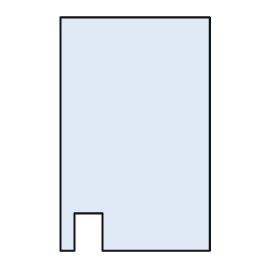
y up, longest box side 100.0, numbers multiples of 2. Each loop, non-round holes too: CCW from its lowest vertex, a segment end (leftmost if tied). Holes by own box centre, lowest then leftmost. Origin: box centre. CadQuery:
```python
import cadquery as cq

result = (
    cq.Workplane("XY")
    .moveTo(-32.0, -50.0)
    .lineTo(-26.0, -50.0)
    .lineTo(-26.0, -34.0)
    .lineTo(-14.0, -34.0)
    .lineTo(-14.0, -50.0)
    .lineTo(32.0, -50.0)
    .lineTo(32.0, 50.0)
    .lineTo(-32.0, 50.0)
    .close()
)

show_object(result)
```